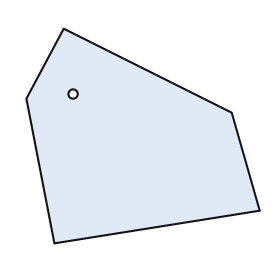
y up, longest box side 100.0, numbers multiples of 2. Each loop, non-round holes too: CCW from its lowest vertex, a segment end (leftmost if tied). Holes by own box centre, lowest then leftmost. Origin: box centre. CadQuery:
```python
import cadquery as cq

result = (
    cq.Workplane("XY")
    .moveTo(-38.0, -46.0)
    .lineTo(50.0, -32.0)
    .lineTo(38.0, 10.0)
    .lineTo(-34.0, 46.0)
    .lineTo(-50.0, 16.0)
    .close()
    .moveTo(-30.0, 18.0)
    .circle(2.0)
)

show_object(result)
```